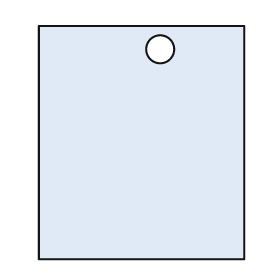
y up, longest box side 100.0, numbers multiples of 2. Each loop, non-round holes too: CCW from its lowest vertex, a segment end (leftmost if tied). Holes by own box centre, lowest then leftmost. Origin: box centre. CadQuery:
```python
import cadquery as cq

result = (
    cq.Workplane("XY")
    .moveTo(-44.0, -50.0)
    .lineTo(44.0, -50.0)
    .lineTo(44.0, 50.0)
    .lineTo(-44.0, 50.0)
    .close()
    .moveTo(8.0, 40.0)
    .circle(6.0)
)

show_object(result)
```